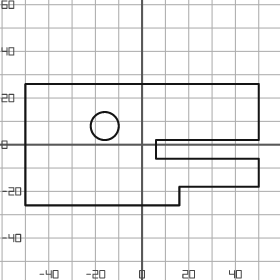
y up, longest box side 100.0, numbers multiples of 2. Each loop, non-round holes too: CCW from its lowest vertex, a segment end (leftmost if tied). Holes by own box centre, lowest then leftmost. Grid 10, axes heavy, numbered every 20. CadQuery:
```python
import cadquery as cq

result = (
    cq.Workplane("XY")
    .moveTo(-50.0, -26.0)
    .lineTo(16.0, -26.0)
    .lineTo(16.0, -18.0)
    .lineTo(50.0, -18.0)
    .lineTo(50.0, -6.0)
    .lineTo(6.0, -6.0)
    .lineTo(6.0, 2.0)
    .lineTo(50.0, 2.0)
    .lineTo(50.0, 26.0)
    .lineTo(-50.0, 26.0)
    .close()
    .moveTo(-16.0, 8.0)
    .circle(6.0)
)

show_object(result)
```